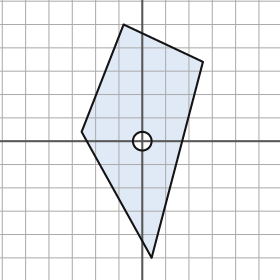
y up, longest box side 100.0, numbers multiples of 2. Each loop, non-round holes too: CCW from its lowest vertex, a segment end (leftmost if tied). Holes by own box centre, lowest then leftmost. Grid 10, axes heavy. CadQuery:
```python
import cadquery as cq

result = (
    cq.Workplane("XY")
    .moveTo(4.0, -50.0)
    .lineTo(26.0, 34.0)
    .lineTo(-8.0, 50.0)
    .lineTo(-26.0, 4.0)
    .close()
    .moveTo(0.0, 0.0)
    .circle(4.0)
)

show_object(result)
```